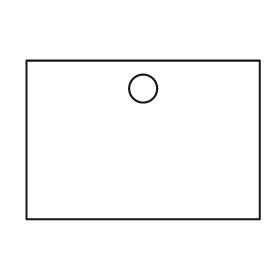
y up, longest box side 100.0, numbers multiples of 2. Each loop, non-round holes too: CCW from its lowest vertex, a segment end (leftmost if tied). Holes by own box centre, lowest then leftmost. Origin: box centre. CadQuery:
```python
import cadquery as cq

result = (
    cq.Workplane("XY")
    .moveTo(-50.0, -34.0)
    .lineTo(50.0, -34.0)
    .lineTo(50.0, 34.0)
    .lineTo(-50.0, 34.0)
    .close()
    .moveTo(0.0, 22.0)
    .circle(6.0)
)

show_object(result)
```